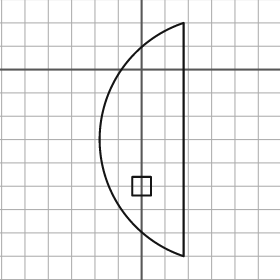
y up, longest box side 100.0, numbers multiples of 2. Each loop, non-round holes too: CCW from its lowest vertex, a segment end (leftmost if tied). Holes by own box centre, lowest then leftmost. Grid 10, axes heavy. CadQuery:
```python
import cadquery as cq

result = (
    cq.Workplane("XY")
    .moveTo(18.0, -80.0)
    .lineTo(18.0, 20.0)
    .threePointArc((-18.0, -30.0), (18.0, -80.0))
    .close()
    .moveTo(-4.0, -54.0)
    .lineTo(4.0, -54.0)
    .lineTo(4.0, -46.0)
    .lineTo(-4.0, -46.0)
    .close()
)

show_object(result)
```